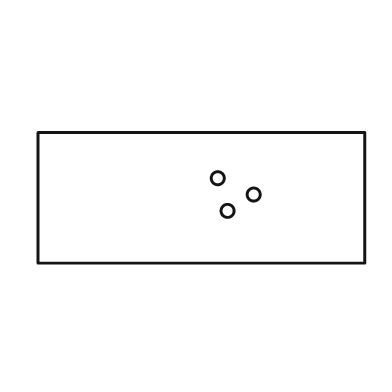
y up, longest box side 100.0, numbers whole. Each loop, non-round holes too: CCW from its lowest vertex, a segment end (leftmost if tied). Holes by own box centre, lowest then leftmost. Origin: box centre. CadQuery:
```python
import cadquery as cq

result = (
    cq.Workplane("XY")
    .moveTo(-50.0, -20.0)
    .lineTo(50.0, -20.0)
    .lineTo(50.0, 20.0)
    .lineTo(-50.0, 20.0)
    .close()
    .moveTo(8.0, -4.0)
    .circle(2.0)
    .moveTo(16.0, 1.0)
    .circle(2.0)
    .moveTo(5.0, 6.0)
    .circle(2.0)
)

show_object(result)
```